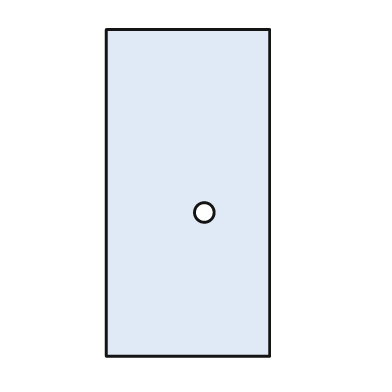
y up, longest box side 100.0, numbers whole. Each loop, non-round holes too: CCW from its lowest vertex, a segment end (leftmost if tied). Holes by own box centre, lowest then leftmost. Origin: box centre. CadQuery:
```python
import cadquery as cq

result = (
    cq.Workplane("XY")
    .moveTo(-25.0, -50.0)
    .lineTo(25.0, -50.0)
    .lineTo(25.0, 50.0)
    .lineTo(-25.0, 50.0)
    .close()
    .moveTo(5.0, -6.0)
    .circle(3.0)
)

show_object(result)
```